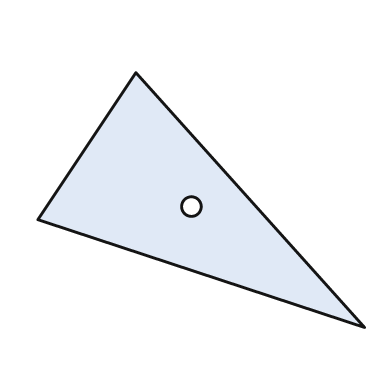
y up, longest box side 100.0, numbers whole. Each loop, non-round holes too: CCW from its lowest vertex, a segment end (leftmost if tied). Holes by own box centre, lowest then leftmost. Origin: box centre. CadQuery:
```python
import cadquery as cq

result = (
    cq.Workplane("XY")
    .moveTo(50.0, -39.0)
    .lineTo(-20.0, 39.0)
    .lineTo(-50.0, -6.0)
    .close()
    .moveTo(-3.0, -2.0)
    .circle(3.0)
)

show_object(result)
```